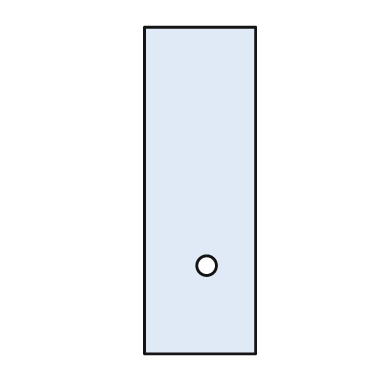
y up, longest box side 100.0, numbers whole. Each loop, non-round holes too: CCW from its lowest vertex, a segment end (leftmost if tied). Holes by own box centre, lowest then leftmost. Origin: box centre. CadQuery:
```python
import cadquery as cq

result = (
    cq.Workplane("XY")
    .moveTo(-17.0, -50.0)
    .lineTo(17.0, -50.0)
    .lineTo(17.0, 50.0)
    .lineTo(-17.0, 50.0)
    .close()
    .moveTo(2.0, -23.0)
    .circle(3.0)
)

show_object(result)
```